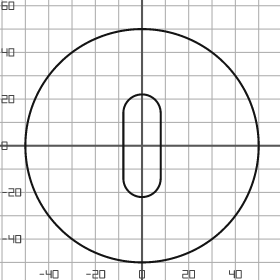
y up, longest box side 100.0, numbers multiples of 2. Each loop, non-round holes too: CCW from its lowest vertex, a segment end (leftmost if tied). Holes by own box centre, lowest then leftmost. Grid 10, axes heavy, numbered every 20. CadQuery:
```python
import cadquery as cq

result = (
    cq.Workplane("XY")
    .moveTo(0.0, 0.0)
    .circle(50.0)
    .moveTo(-8.0, -14.0)
    .threePointArc((0.0, -22.0), (8.0, -14.0))
    .lineTo(8.0, 14.0)
    .threePointArc((0.0, 22.0), (-8.0, 14.0))
    .close()
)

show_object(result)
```